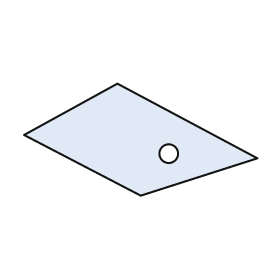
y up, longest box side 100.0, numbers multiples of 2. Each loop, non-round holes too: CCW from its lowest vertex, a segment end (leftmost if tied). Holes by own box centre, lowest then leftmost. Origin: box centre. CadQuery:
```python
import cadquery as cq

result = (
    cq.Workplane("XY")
    .moveTo(0.0, -24.0)
    .lineTo(50.0, -8.0)
    .lineTo(-10.0, 24.0)
    .lineTo(-50.0, 2.0)
    .close()
    .moveTo(12.0, -6.0)
    .circle(4.0)
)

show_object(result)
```